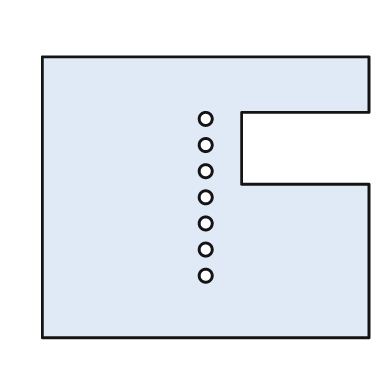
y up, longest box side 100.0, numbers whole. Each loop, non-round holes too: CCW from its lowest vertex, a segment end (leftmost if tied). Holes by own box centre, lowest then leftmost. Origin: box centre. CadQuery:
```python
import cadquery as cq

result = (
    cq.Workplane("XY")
    .moveTo(-50.0, -43.0)
    .lineTo(50.0, -43.0)
    .lineTo(50.0, 4.0)
    .lineTo(11.0, 4.0)
    .lineTo(11.0, 26.0)
    .lineTo(50.0, 26.0)
    .lineTo(50.0, 43.0)
    .lineTo(-50.0, 43.0)
    .close()
    .moveTo(0.0, -24.0)
    .circle(2.0)
    .moveTo(0.0, -16.0)
    .circle(2.0)
    .moveTo(0.0, -8.0)
    .circle(2.0)
    .moveTo(0.0, 0.0)
    .circle(2.0)
    .moveTo(0.0, 8.0)
    .circle(2.0)
    .moveTo(0.0, 16.0)
    .circle(2.0)
    .moveTo(0.0, 24.0)
    .circle(2.0)
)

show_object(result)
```